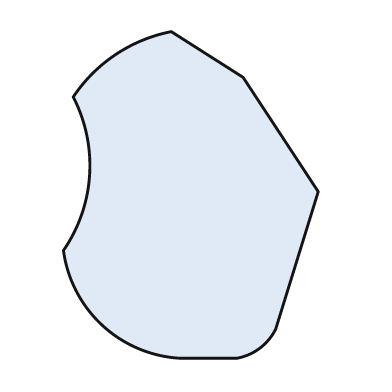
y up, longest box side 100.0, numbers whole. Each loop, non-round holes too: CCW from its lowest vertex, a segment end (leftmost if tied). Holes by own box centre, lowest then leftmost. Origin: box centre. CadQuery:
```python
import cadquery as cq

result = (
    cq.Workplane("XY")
    .moveTo(-3.0, -50.0)
    .lineTo(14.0, -50.0)
    .threePointArc((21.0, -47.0), (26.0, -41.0))
    .lineTo(39.0, 1.0)
    .lineTo(16.0, 36.0)
    .lineTo(-6.0, 50.0)
    .threePointArc((-23.0, 43.0), (-36.0, 30.0))
    .threePointArc((-31.0, 6.0), (-39.0, -17.0))
    .threePointArc((-27.0, -40.0), (-3.0, -50.0))
    .close()
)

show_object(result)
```